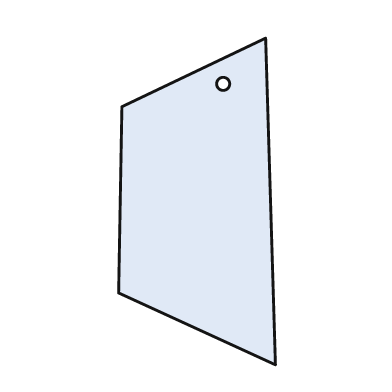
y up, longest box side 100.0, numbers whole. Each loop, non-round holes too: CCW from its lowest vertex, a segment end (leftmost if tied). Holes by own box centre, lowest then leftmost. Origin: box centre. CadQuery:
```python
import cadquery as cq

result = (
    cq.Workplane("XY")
    .moveTo(24.0, -50.0)
    .lineTo(21.0, 50.0)
    .lineTo(-23.0, 29.0)
    .lineTo(-24.0, -28.0)
    .close()
    .moveTo(8.0, 36.0)
    .circle(2.0)
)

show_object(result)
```